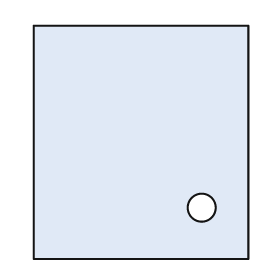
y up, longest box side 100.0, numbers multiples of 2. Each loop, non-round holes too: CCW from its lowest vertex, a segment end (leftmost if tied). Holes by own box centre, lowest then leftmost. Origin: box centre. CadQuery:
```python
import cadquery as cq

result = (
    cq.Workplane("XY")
    .moveTo(-46.0, -50.0)
    .lineTo(46.0, -50.0)
    .lineTo(46.0, 50.0)
    .lineTo(-46.0, 50.0)
    .close()
    .moveTo(26.0, -28.0)
    .circle(6.0)
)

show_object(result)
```